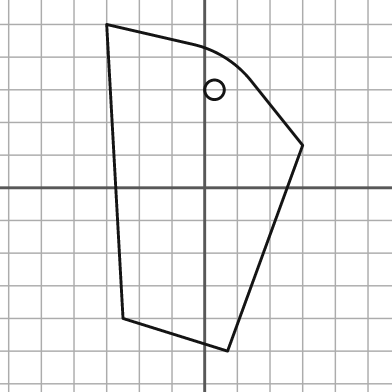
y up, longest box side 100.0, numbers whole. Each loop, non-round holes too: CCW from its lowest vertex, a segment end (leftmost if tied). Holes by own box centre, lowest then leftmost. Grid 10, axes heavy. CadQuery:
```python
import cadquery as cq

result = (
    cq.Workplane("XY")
    .moveTo(7.0, -50.0)
    .lineTo(30.0, 13.0)
    .lineTo(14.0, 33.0)
    .threePointArc((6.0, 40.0), (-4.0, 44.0))
    .lineTo(-30.0, 50.0)
    .lineTo(-25.0, -40.0)
    .close()
    .moveTo(3.0, 30.0)
    .circle(3.0)
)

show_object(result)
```